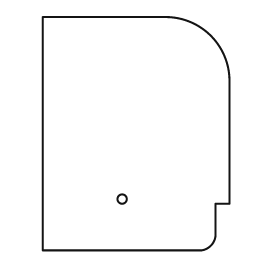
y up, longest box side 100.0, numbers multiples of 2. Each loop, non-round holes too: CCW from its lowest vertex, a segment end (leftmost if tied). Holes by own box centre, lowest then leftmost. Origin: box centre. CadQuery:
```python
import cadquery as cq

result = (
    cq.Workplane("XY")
    .moveTo(-40.0, -50.0)
    .lineTo(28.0, -50.0)
    .threePointArc((32.0, -48.0), (34.0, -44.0))
    .lineTo(34.0, -30.0)
    .lineTo(40.0, -30.0)
    .lineTo(40.0, 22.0)
    .threePointArc((32.0, 42.0), (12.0, 50.0))
    .lineTo(-40.0, 50.0)
    .close()
    .moveTo(-6.0, -28.0)
    .circle(2.0)
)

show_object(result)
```